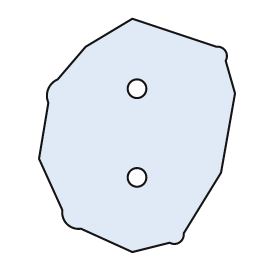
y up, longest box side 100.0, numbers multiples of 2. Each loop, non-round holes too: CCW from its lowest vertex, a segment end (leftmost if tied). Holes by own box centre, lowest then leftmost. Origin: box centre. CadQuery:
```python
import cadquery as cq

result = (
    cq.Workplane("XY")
    .moveTo(-2.0, -50.0)
    .lineTo(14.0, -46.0)
    .threePointArc((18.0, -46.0), (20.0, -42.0))
    .lineTo(36.0, -16.0)
    .lineTo(42.0, 18.0)
    .lineTo(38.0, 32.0)
    .threePointArc((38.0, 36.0), (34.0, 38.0))
    .lineTo(-2.0, 50.0)
    .lineTo(-22.0, 38.0)
    .lineTo(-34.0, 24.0)
    .threePointArc((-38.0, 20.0), (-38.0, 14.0))
    .lineTo(-42.0, -10.0)
    .lineTo(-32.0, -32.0)
    .threePointArc((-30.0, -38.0), (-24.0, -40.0))
    .close()
    .moveTo(0.0, -18.0)
    .circle(4.0)
    .moveTo(0.0, 20.0)
    .circle(4.0)
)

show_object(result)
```